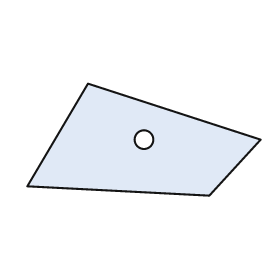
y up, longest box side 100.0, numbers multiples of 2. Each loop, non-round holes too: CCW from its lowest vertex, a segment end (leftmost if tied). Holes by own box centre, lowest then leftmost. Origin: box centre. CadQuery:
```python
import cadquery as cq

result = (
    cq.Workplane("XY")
    .moveTo(28.0, -24.0)
    .lineTo(50.0, 0.0)
    .lineTo(-24.0, 24.0)
    .lineTo(-50.0, -20.0)
    .close()
    .moveTo(0.0, 0.0)
    .circle(4.0)
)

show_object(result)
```